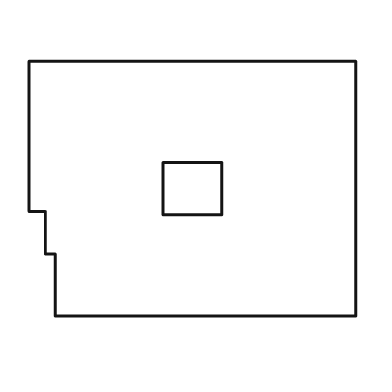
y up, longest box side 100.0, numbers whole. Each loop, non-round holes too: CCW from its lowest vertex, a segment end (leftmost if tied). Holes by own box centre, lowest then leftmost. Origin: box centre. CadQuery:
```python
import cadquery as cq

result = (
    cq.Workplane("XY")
    .moveTo(-42.0, -39.0)
    .lineTo(50.0, -39.0)
    .lineTo(50.0, 39.0)
    .lineTo(-50.0, 39.0)
    .lineTo(-50.0, -7.0)
    .lineTo(-45.0, -7.0)
    .lineTo(-45.0, -20.0)
    .lineTo(-42.0, -20.0)
    .close()
    .moveTo(-9.0, -8.0)
    .lineTo(9.0, -8.0)
    .lineTo(9.0, 8.0)
    .lineTo(-9.0, 8.0)
    .close()
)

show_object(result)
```